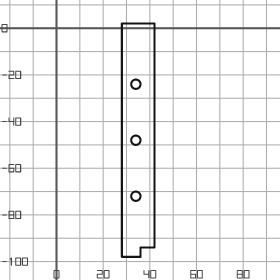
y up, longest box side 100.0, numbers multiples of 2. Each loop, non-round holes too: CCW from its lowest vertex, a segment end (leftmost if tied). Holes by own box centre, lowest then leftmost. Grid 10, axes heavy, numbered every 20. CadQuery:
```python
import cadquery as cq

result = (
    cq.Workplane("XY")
    .moveTo(28.0, -98.0)
    .lineTo(36.0, -98.0)
    .lineTo(36.0, -94.0)
    .lineTo(42.0, -94.0)
    .lineTo(42.0, 2.0)
    .lineTo(28.0, 2.0)
    .close()
    .moveTo(34.0, -72.0)
    .circle(2.0)
    .moveTo(34.0, -48.0)
    .circle(2.0)
    .moveTo(34.0, -24.0)
    .circle(2.0)
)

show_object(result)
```